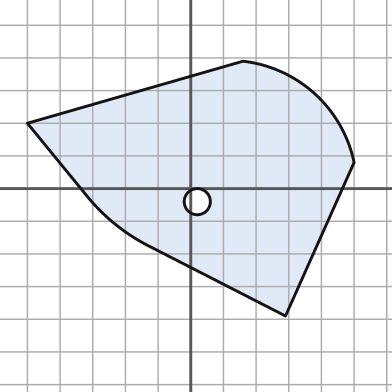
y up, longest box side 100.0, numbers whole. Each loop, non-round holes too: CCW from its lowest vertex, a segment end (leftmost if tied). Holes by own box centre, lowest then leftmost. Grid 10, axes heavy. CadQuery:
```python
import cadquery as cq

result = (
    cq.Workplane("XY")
    .moveTo(29.0, -39.0)
    .lineTo(50.0, 8.0)
    .threePointArc((38.0, 29.0), (16.0, 39.0))
    .lineTo(-50.0, 20.0)
    .lineTo(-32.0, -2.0)
    .threePointArc((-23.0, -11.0), (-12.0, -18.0))
    .close()
    .moveTo(2.0, -4.0)
    .circle(4.0)
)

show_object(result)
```